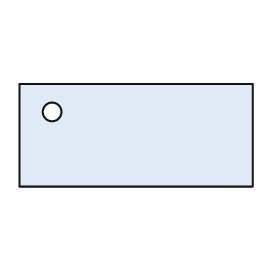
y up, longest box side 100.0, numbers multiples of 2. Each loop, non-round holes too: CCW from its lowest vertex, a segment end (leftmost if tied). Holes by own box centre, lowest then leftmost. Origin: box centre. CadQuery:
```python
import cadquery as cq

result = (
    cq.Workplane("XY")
    .moveTo(-50.0, -22.0)
    .lineTo(50.0, -22.0)
    .lineTo(50.0, 22.0)
    .lineTo(-50.0, 22.0)
    .close()
    .moveTo(-36.0, 10.0)
    .circle(4.0)
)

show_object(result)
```